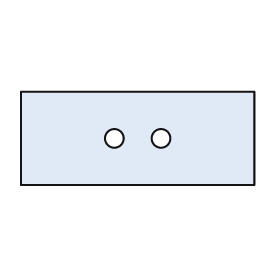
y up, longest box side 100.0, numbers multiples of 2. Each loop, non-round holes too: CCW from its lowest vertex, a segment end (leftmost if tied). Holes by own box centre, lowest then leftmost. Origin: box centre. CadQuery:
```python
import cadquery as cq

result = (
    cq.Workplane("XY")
    .moveTo(-50.0, -20.0)
    .lineTo(50.0, -20.0)
    .lineTo(50.0, 20.0)
    .lineTo(-50.0, 20.0)
    .close()
    .moveTo(-10.0, 0.0)
    .circle(4.0)
    .moveTo(10.0, 0.0)
    .circle(4.0)
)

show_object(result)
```